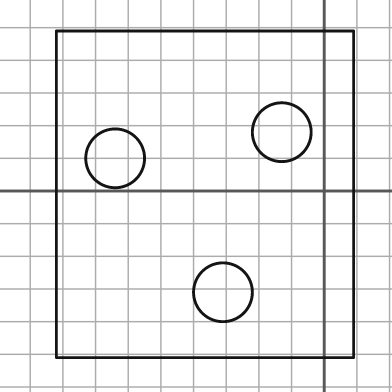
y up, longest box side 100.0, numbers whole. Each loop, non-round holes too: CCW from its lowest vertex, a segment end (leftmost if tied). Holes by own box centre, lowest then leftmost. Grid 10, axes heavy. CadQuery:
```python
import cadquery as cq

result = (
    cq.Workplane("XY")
    .moveTo(-82.0, -51.0)
    .lineTo(9.0, -51.0)
    .lineTo(9.0, 49.0)
    .lineTo(-82.0, 49.0)
    .close()
    .moveTo(-31.0, -31.0)
    .circle(9.0)
    .moveTo(-64.0, 10.0)
    .circle(9.0)
    .moveTo(-13.0, 18.0)
    .circle(9.0)
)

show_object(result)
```